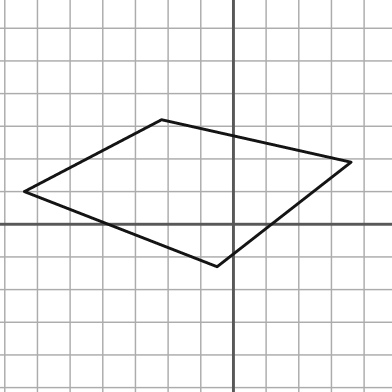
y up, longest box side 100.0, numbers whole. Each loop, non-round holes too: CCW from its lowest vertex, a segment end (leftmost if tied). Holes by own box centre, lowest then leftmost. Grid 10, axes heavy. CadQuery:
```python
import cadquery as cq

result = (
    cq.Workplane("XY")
    .moveTo(-5.0, -13.0)
    .lineTo(36.0, 19.0)
    .lineTo(-22.0, 32.0)
    .lineTo(-64.0, 10.0)
    .close()
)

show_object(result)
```